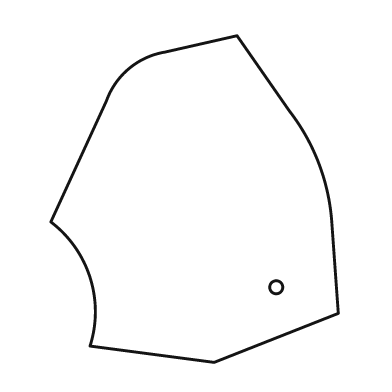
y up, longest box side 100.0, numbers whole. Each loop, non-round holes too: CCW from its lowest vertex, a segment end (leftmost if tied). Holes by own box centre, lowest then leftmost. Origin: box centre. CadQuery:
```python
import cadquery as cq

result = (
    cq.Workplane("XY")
    .moveTo(6.0, -50.0)
    .lineTo(44.0, -35.0)
    .lineTo(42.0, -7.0)
    .threePointArc((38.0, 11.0), (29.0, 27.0))
    .lineTo(13.0, 50.0)
    .lineTo(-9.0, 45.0)
    .threePointArc((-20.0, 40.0), (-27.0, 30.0))
    .lineTo(-44.0, -7.0)
    .threePointArc((-32.0, -24.0), (-32.0, -45.0))
    .close()
    .moveTo(25.0, -27.0)
    .circle(2.0)
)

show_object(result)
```